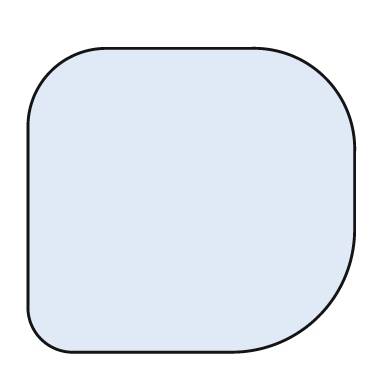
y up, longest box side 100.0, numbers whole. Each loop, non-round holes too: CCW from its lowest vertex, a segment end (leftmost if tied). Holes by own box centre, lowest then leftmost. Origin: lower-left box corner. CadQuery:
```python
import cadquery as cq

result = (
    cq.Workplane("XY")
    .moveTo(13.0, 0.0)
    .lineTo(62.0, 0.0)
    .threePointArc((89.0, 11.0), (100.0, 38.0))
    .lineTo(100.0, 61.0)
    .threePointArc((91.0, 84.0), (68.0, 93.0))
    .lineTo(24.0, 93.0)
    .threePointArc((7.0, 86.0), (0.0, 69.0))
    .lineTo(0.0, 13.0)
    .threePointArc((4.0, 4.0), (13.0, 0.0))
    .close()
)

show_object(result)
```